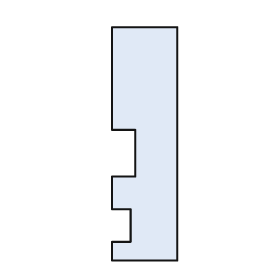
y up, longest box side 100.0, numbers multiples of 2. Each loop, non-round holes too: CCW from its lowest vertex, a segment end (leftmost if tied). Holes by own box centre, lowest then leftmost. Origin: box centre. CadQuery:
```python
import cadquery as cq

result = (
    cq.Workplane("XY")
    .moveTo(-14.0, -50.0)
    .lineTo(14.0, -50.0)
    .lineTo(14.0, 50.0)
    .lineTo(-14.0, 50.0)
    .lineTo(-14.0, 6.0)
    .lineTo(-4.0, 6.0)
    .lineTo(-4.0, -14.0)
    .lineTo(-14.0, -14.0)
    .lineTo(-14.0, -28.0)
    .lineTo(-6.0, -28.0)
    .lineTo(-6.0, -42.0)
    .lineTo(-14.0, -42.0)
    .close()
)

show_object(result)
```